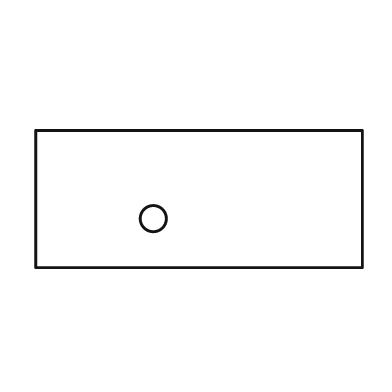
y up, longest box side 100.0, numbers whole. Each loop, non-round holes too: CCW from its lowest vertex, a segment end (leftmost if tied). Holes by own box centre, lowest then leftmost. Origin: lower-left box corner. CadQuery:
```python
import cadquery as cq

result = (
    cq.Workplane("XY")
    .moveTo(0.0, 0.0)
    .lineTo(100.0, 0.0)
    .lineTo(100.0, 42.0)
    .lineTo(0.0, 42.0)
    .close()
    .moveTo(36.0, 15.0)
    .circle(4.0)
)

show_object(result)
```